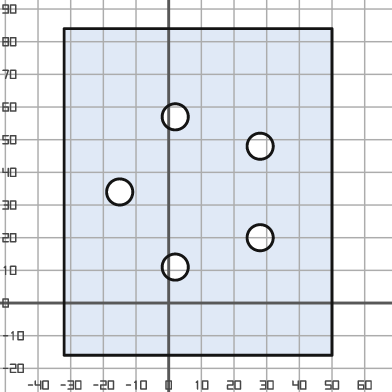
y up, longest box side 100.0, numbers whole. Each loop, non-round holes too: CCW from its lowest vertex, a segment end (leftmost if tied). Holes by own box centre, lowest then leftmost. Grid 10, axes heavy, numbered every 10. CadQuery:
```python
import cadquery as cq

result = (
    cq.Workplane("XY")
    .moveTo(-32.0, -16.0)
    .lineTo(50.0, -16.0)
    .lineTo(50.0, 84.0)
    .lineTo(-32.0, 84.0)
    .close()
    .moveTo(2.0, 11.0)
    .circle(4.0)
    .moveTo(28.0, 20.0)
    .circle(4.0)
    .moveTo(-15.0, 34.0)
    .circle(4.0)
    .moveTo(28.0, 48.0)
    .circle(4.0)
    .moveTo(2.0, 57.0)
    .circle(4.0)
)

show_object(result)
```